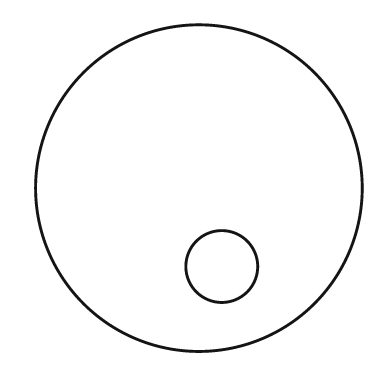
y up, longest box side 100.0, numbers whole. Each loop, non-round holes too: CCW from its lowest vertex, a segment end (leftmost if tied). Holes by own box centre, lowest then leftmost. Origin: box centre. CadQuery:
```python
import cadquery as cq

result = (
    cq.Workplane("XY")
    .moveTo(0.0, 0.0)
    .circle(50.0)
    .moveTo(7.0, -24.0)
    .circle(11.0)
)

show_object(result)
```